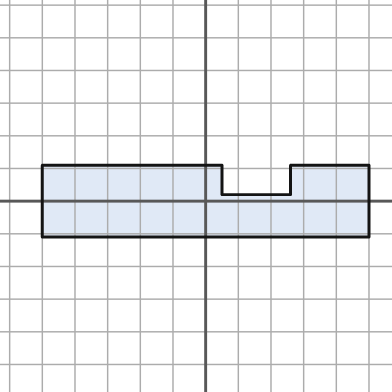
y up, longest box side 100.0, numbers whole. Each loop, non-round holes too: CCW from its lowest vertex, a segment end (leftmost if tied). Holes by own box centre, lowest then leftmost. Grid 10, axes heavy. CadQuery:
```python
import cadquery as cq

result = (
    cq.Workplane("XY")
    .moveTo(-50.0, -11.0)
    .lineTo(50.0, -11.0)
    .lineTo(50.0, 11.0)
    .lineTo(26.0, 11.0)
    .lineTo(26.0, 2.0)
    .lineTo(5.0, 2.0)
    .lineTo(5.0, 11.0)
    .lineTo(-50.0, 11.0)
    .close()
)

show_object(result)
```